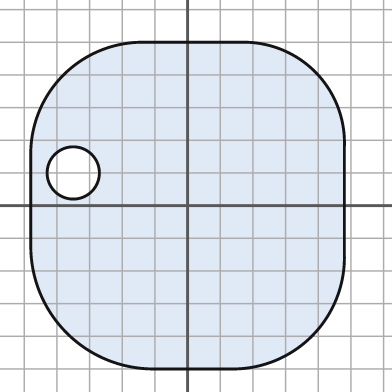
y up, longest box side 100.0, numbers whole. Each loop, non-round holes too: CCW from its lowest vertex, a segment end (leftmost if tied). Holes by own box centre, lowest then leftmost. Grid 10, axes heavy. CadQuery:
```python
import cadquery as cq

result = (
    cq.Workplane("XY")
    .moveTo(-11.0, -50.0)
    .lineTo(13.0, -50.0)
    .threePointArc((38.0, -40.0), (48.0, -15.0))
    .lineTo(48.0, 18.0)
    .threePointArc((39.0, 41.0), (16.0, 50.0))
    .lineTo(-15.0, 50.0)
    .threePointArc((-38.0, 40.0), (-48.0, 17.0))
    .lineTo(-48.0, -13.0)
    .threePointArc((-37.0, -39.0), (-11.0, -50.0))
    .close()
    .moveTo(-35.0, 10.0)
    .circle(8.0)
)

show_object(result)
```